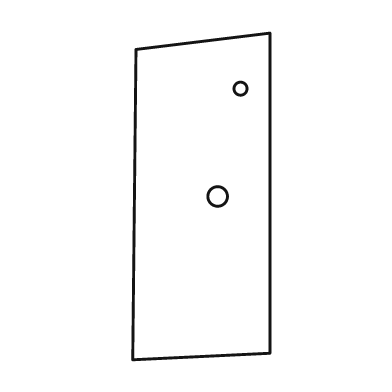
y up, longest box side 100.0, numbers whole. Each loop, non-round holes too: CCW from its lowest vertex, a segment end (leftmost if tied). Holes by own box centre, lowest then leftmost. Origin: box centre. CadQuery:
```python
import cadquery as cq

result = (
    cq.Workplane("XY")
    .moveTo(-21.0, -50.0)
    .lineTo(21.0, -48.0)
    .lineTo(21.0, 50.0)
    .lineTo(-20.0, 45.0)
    .close()
    .moveTo(5.0, 0.0)
    .circle(3.0)
    .moveTo(12.0, 33.0)
    .circle(2.0)
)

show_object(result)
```